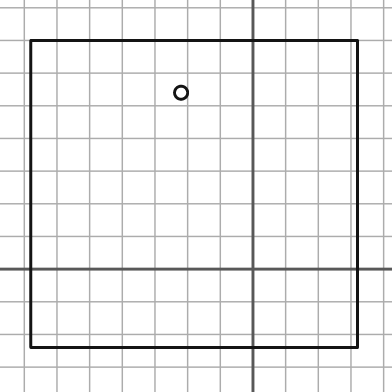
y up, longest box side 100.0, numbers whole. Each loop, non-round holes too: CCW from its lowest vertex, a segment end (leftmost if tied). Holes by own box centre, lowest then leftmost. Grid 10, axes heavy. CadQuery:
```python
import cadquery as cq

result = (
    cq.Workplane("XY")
    .moveTo(-68.0, -24.0)
    .lineTo(32.0, -24.0)
    .lineTo(32.0, 70.0)
    .lineTo(-68.0, 70.0)
    .close()
    .moveTo(-22.0, 54.0)
    .circle(2.0)
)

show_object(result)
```